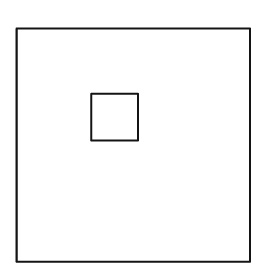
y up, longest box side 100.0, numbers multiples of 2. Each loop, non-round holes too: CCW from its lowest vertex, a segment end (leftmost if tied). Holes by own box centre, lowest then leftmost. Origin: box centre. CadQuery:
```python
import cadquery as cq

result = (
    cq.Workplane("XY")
    .moveTo(-50.0, -50.0)
    .lineTo(50.0, -50.0)
    .lineTo(50.0, 50.0)
    .lineTo(-50.0, 50.0)
    .close()
    .moveTo(-18.0, 2.0)
    .lineTo(2.0, 2.0)
    .lineTo(2.0, 22.0)
    .lineTo(-18.0, 22.0)
    .close()
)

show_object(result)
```